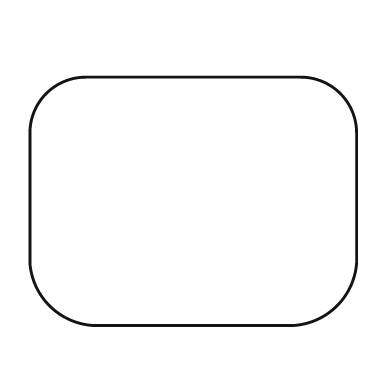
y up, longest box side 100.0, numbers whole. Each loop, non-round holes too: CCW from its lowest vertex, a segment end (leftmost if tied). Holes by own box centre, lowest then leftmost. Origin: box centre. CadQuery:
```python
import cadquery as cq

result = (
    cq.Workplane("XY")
    .moveTo(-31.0, -38.0)
    .lineTo(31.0, -38.0)
    .threePointArc((44.0, -32.0), (50.0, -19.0))
    .lineTo(50.0, 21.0)
    .threePointArc((45.0, 33.0), (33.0, 38.0))
    .lineTo(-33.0, 38.0)
    .threePointArc((-45.0, 33.0), (-50.0, 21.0))
    .lineTo(-50.0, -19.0)
    .threePointArc((-44.0, -32.0), (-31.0, -38.0))
    .close()
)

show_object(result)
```